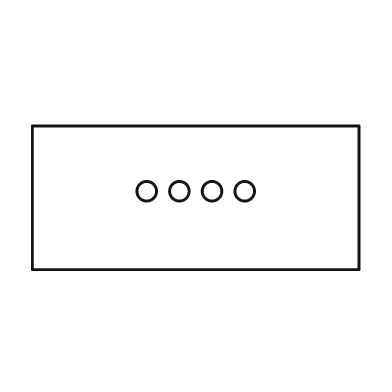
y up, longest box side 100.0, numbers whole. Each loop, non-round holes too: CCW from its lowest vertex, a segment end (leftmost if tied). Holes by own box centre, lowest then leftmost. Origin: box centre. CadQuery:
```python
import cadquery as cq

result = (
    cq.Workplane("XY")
    .moveTo(-50.0, -22.0)
    .lineTo(50.0, -22.0)
    .lineTo(50.0, 22.0)
    .lineTo(-50.0, 22.0)
    .close()
    .moveTo(-15.0, 2.0)
    .circle(3.0)
    .moveTo(-5.0, 2.0)
    .circle(3.0)
    .moveTo(5.0, 2.0)
    .circle(3.0)
    .moveTo(15.0, 2.0)
    .circle(3.0)
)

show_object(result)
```